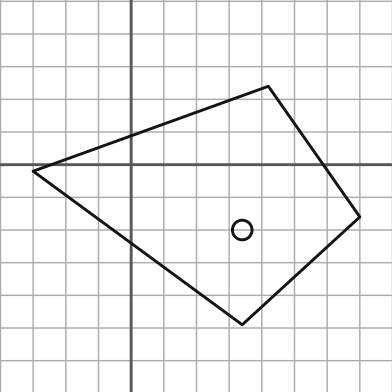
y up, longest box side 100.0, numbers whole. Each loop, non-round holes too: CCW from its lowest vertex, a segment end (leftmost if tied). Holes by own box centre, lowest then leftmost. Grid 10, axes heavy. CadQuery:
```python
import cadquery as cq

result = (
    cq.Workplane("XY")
    .moveTo(34.0, -49.0)
    .lineTo(70.0, -16.0)
    .lineTo(42.0, 24.0)
    .lineTo(-30.0, -2.0)
    .close()
    .moveTo(34.0, -20.0)
    .circle(3.0)
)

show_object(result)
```